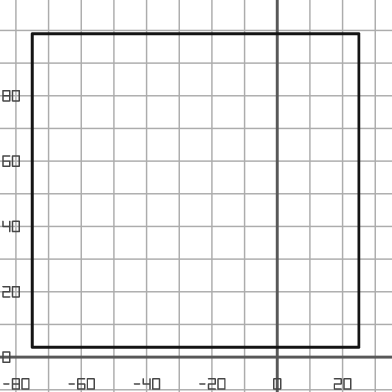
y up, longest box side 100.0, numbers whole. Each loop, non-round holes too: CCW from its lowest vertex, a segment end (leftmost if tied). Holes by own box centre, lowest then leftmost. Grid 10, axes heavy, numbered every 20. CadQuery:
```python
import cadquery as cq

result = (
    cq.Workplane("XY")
    .moveTo(-75.0, 3.0)
    .lineTo(25.0, 3.0)
    .lineTo(25.0, 99.0)
    .lineTo(-75.0, 99.0)
    .close()
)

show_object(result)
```